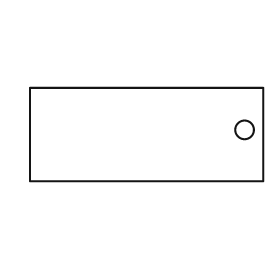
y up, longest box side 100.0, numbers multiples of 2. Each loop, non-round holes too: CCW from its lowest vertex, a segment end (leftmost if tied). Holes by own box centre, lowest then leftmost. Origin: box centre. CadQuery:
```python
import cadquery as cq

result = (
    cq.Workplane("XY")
    .moveTo(-50.0, -20.0)
    .lineTo(50.0, -20.0)
    .lineTo(50.0, 20.0)
    .lineTo(-50.0, 20.0)
    .close()
    .moveTo(42.0, 2.0)
    .circle(4.0)
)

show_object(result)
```